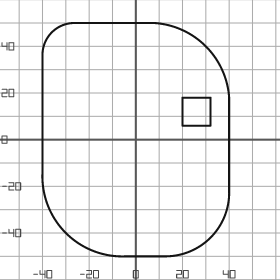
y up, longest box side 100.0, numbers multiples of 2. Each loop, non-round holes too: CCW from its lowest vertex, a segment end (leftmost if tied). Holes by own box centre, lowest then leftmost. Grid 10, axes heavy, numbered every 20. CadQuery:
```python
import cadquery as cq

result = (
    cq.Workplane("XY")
    .moveTo(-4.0, -50.0)
    .lineTo(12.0, -50.0)
    .threePointArc((32.0, -42.0), (40.0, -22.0))
    .lineTo(40.0, 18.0)
    .threePointArc((30.0, 40.0), (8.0, 50.0))
    .lineTo(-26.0, 50.0)
    .threePointArc((-36.0, 46.0), (-40.0, 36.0))
    .lineTo(-40.0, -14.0)
    .threePointArc((-30.0, -40.0), (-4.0, -50.0))
    .close()
    .moveTo(20.0, 6.0)
    .lineTo(32.0, 6.0)
    .lineTo(32.0, 18.0)
    .lineTo(20.0, 18.0)
    .close()
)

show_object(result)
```